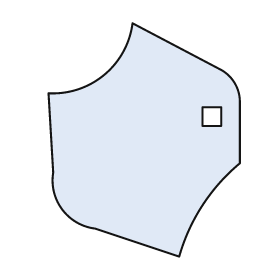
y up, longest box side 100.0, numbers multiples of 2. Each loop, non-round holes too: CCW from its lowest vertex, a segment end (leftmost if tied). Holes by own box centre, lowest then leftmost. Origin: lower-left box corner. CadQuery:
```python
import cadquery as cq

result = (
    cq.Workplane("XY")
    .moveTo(56.0, 0.0)
    .threePointArc((66.0, 22.0), (82.0, 40.0))
    .lineTo(82.0, 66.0)
    .threePointArc((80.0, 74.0), (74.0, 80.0))
    .lineTo(36.0, 100.0)
    .threePointArc((24.0, 78.0), (0.0, 70.0))
    .lineTo(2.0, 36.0)
    .threePointArc((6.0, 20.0), (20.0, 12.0))
    .close()
    .moveTo(66.0, 56.0)
    .lineTo(74.0, 56.0)
    .lineTo(74.0, 64.0)
    .lineTo(66.0, 64.0)
    .close()
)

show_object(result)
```